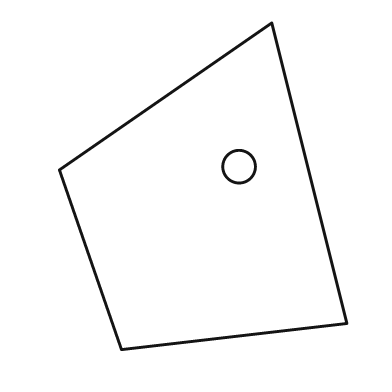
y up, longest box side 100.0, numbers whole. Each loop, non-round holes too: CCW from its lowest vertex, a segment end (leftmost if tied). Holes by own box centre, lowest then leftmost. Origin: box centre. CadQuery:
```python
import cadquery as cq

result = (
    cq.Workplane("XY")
    .moveTo(-25.0, -50.0)
    .lineTo(44.0, -42.0)
    .lineTo(21.0, 50.0)
    .lineTo(-44.0, 5.0)
    .close()
    .moveTo(11.0, 6.0)
    .circle(5.0)
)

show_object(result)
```